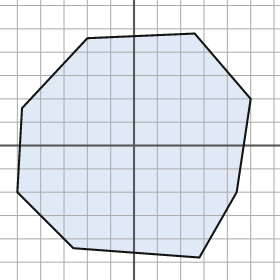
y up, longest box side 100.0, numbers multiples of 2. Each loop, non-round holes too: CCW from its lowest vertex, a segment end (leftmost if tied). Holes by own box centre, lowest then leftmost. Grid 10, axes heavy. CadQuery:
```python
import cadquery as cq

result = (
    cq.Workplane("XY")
    .moveTo(28.0, -48.0)
    .lineTo(44.0, -20.0)
    .lineTo(50.0, 20.0)
    .lineTo(26.0, 48.0)
    .lineTo(-20.0, 46.0)
    .lineTo(-48.0, 16.0)
    .lineTo(-50.0, -20.0)
    .lineTo(-26.0, -44.0)
    .close()
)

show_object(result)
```